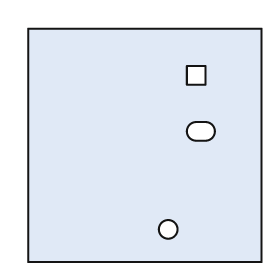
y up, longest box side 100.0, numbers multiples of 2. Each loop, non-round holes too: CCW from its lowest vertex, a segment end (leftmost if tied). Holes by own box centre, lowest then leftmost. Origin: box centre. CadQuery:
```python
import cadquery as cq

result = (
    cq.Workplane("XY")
    .moveTo(-50.0, -50.0)
    .lineTo(50.0, -50.0)
    .lineTo(50.0, 50.0)
    .lineTo(-50.0, 50.0)
    .close()
    .moveTo(10.0, -36.0)
    .circle(4.0)
    .moveTo(22.0, 2.0)
    .lineTo(26.0, 2.0)
    .threePointArc((30.0, 6.0), (26.0, 10.0))
    .lineTo(22.0, 10.0)
    .threePointArc((18.0, 6.0), (22.0, 2.0))
    .close()
    .moveTo(18.0, 26.0)
    .lineTo(26.0, 26.0)
    .lineTo(26.0, 34.0)
    .lineTo(18.0, 34.0)
    .close()
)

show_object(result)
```